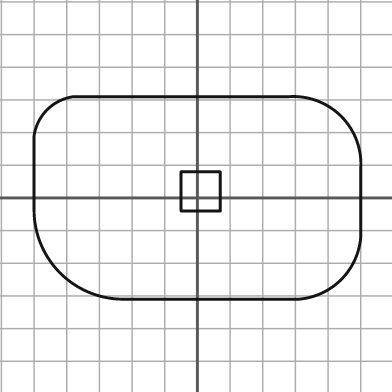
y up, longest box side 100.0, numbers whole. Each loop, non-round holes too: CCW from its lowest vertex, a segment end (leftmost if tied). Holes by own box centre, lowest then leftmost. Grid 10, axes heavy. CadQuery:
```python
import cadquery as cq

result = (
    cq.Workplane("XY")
    .moveTo(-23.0, -31.0)
    .lineTo(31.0, -31.0)
    .threePointArc((44.0, -25.0), (50.0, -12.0))
    .lineTo(50.0, 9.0)
    .threePointArc((44.0, 25.0), (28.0, 31.0))
    .lineTo(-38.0, 31.0)
    .threePointArc((-46.0, 27.0), (-50.0, 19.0))
    .lineTo(-50.0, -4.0)
    .threePointArc((-42.0, -23.0), (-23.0, -31.0))
    .close()
    .moveTo(-5.0, -4.0)
    .lineTo(7.0, -4.0)
    .lineTo(7.0, 8.0)
    .lineTo(-5.0, 8.0)
    .close()
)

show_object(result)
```